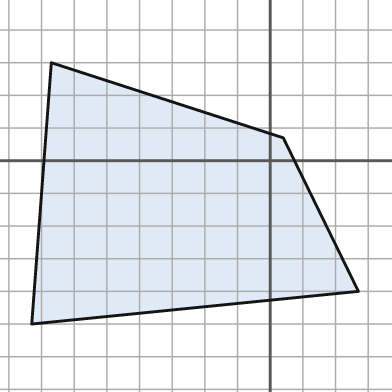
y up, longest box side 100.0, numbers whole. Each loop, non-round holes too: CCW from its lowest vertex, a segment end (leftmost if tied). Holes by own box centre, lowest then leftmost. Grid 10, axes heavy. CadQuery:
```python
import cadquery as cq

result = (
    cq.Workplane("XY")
    .moveTo(-73.0, -50.0)
    .lineTo(27.0, -40.0)
    .lineTo(4.0, 7.0)
    .lineTo(-67.0, 30.0)
    .close()
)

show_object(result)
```